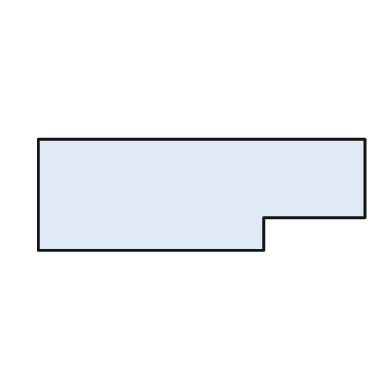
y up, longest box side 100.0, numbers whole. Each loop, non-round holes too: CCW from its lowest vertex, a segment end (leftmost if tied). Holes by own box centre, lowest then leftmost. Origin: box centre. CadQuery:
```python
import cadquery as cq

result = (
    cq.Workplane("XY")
    .moveTo(-50.0, -17.0)
    .lineTo(19.0, -17.0)
    .lineTo(19.0, -7.0)
    .lineTo(50.0, -7.0)
    .lineTo(50.0, 17.0)
    .lineTo(-50.0, 17.0)
    .close()
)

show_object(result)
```